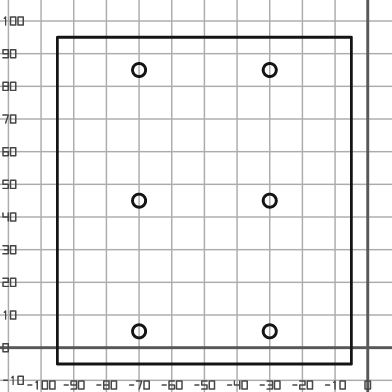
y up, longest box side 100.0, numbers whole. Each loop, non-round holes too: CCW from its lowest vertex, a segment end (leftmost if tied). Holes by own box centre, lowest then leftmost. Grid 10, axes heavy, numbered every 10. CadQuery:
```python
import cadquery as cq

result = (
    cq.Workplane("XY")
    .moveTo(-95.0, -5.0)
    .lineTo(-5.0, -5.0)
    .lineTo(-5.0, 95.0)
    .lineTo(-95.0, 95.0)
    .close()
    .moveTo(-70.0, 5.0)
    .circle(2.0)
    .moveTo(-30.0, 5.0)
    .circle(2.0)
    .moveTo(-70.0, 45.0)
    .circle(2.0)
    .moveTo(-30.0, 45.0)
    .circle(2.0)
    .moveTo(-70.0, 85.0)
    .circle(2.0)
    .moveTo(-30.0, 85.0)
    .circle(2.0)
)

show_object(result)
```